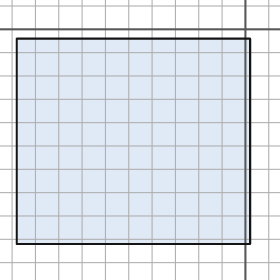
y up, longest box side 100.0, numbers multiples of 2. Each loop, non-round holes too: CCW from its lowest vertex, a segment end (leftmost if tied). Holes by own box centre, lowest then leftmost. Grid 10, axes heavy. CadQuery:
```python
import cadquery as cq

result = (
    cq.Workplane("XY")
    .moveTo(-98.0, -92.0)
    .lineTo(2.0, -92.0)
    .lineTo(2.0, -4.0)
    .lineTo(-98.0, -4.0)
    .close()
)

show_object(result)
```